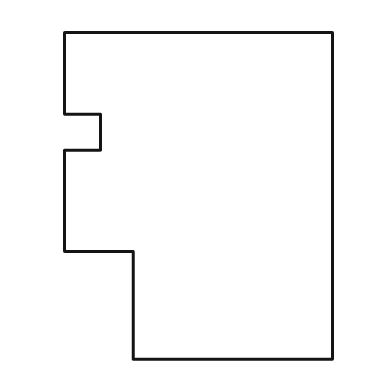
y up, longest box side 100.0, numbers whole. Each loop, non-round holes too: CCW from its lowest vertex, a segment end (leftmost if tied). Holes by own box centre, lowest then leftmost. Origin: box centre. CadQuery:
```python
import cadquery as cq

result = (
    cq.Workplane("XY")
    .moveTo(-20.0, -50.0)
    .lineTo(41.0, -50.0)
    .lineTo(41.0, 50.0)
    .lineTo(-41.0, 50.0)
    .lineTo(-41.0, 25.0)
    .lineTo(-30.0, 25.0)
    .lineTo(-30.0, 14.0)
    .lineTo(-41.0, 14.0)
    .lineTo(-41.0, -17.0)
    .lineTo(-20.0, -17.0)
    .close()
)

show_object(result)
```